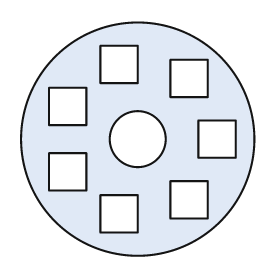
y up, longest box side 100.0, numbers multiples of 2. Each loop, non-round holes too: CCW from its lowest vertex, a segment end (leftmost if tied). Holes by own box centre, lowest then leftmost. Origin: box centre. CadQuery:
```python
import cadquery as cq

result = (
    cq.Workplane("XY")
    .moveTo(0.0, 0.0)
    .circle(50.0)
    .moveTo(-16.0, -40.0)
    .lineTo(0.0, -40.0)
    .lineTo(0.0, -24.0)
    .lineTo(-16.0, -24.0)
    .close()
    .moveTo(14.0, -34.0)
    .lineTo(30.0, -34.0)
    .lineTo(30.0, -18.0)
    .lineTo(14.0, -18.0)
    .close()
    .moveTo(-38.0, -22.0)
    .lineTo(-22.0, -22.0)
    .lineTo(-22.0, -6.0)
    .lineTo(-38.0, -6.0)
    .close()
    .moveTo(0.0, 0.0)
    .circle(12.0)
    .moveTo(26.0, -8.0)
    .lineTo(42.0, -8.0)
    .lineTo(42.0, 8.0)
    .lineTo(26.0, 8.0)
    .close()
    .moveTo(-38.0, 6.0)
    .lineTo(-22.0, 6.0)
    .lineTo(-22.0, 22.0)
    .lineTo(-38.0, 22.0)
    .close()
    .moveTo(14.0, 18.0)
    .lineTo(30.0, 18.0)
    .lineTo(30.0, 34.0)
    .lineTo(14.0, 34.0)
    .close()
    .moveTo(-16.0, 24.0)
    .lineTo(0.0, 24.0)
    .lineTo(0.0, 40.0)
    .lineTo(-16.0, 40.0)
    .close()
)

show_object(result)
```